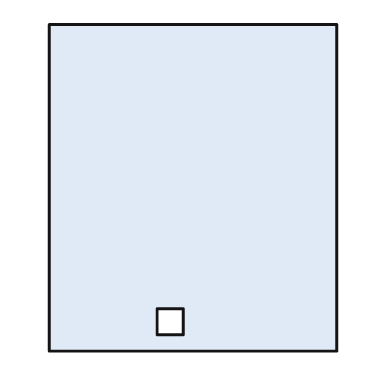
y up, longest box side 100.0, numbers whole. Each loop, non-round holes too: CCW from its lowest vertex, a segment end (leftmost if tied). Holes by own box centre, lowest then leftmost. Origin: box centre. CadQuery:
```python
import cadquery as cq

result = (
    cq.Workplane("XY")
    .moveTo(-44.0, -50.0)
    .lineTo(44.0, -50.0)
    .lineTo(44.0, 50.0)
    .lineTo(-44.0, 50.0)
    .close()
    .moveTo(-11.0, -45.0)
    .lineTo(-3.0, -45.0)
    .lineTo(-3.0, -37.0)
    .lineTo(-11.0, -37.0)
    .close()
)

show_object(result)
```